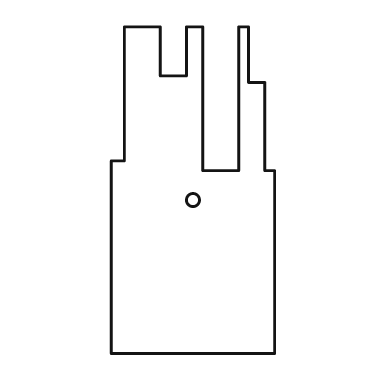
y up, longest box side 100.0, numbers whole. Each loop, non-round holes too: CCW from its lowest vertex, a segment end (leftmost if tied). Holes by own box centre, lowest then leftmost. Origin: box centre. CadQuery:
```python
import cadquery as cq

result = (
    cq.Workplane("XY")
    .moveTo(-25.0, -50.0)
    .lineTo(25.0, -50.0)
    .lineTo(25.0, 6.0)
    .lineTo(22.0, 6.0)
    .lineTo(22.0, 33.0)
    .lineTo(17.0, 33.0)
    .lineTo(17.0, 50.0)
    .lineTo(14.0, 50.0)
    .lineTo(14.0, 6.0)
    .lineTo(3.0, 6.0)
    .lineTo(3.0, 50.0)
    .lineTo(-2.0, 50.0)
    .lineTo(-2.0, 35.0)
    .lineTo(-10.0, 35.0)
    .lineTo(-10.0, 50.0)
    .lineTo(-21.0, 50.0)
    .lineTo(-21.0, 9.0)
    .lineTo(-25.0, 9.0)
    .close()
    .moveTo(0.0, -3.0)
    .circle(2.0)
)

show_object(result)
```